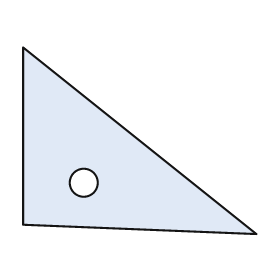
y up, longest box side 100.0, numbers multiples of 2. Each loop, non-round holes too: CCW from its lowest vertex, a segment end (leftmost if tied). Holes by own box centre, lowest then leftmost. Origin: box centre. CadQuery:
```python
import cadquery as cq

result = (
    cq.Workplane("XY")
    .moveTo(50.0, -40.0)
    .lineTo(-50.0, 40.0)
    .lineTo(-50.0, -36.0)
    .close()
    .moveTo(-24.0, -18.0)
    .circle(6.0)
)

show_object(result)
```